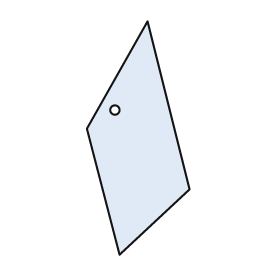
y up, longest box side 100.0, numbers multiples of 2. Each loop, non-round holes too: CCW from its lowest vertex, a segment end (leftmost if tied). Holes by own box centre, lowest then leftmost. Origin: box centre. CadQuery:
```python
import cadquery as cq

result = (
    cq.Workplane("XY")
    .moveTo(-8.0, -50.0)
    .lineTo(22.0, -22.0)
    .lineTo(4.0, 50.0)
    .lineTo(-22.0, 4.0)
    .close()
    .moveTo(-10.0, 12.0)
    .circle(2.0)
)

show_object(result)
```